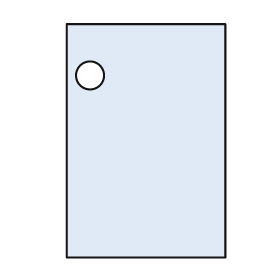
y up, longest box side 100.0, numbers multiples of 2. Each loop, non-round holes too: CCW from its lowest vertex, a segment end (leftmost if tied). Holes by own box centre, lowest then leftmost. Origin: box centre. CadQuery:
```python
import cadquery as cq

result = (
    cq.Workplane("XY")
    .moveTo(-34.0, -50.0)
    .lineTo(34.0, -50.0)
    .lineTo(34.0, 50.0)
    .lineTo(-34.0, 50.0)
    .close()
    .moveTo(-24.0, 28.0)
    .circle(6.0)
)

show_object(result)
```